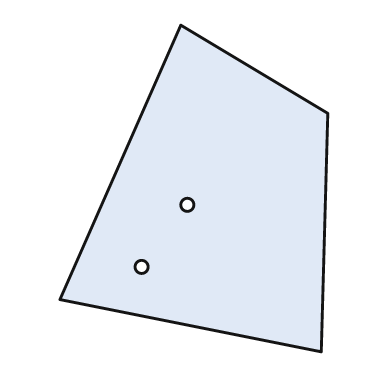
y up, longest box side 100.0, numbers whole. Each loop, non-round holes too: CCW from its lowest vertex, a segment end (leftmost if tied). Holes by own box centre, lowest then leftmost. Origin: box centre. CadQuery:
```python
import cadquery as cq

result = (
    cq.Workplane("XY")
    .moveTo(39.0, -50.0)
    .lineTo(41.0, 23.0)
    .lineTo(-4.0, 50.0)
    .lineTo(-41.0, -34.0)
    .close()
    .moveTo(-16.0, -24.0)
    .circle(2.0)
    .moveTo(-2.0, -5.0)
    .circle(2.0)
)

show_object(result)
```